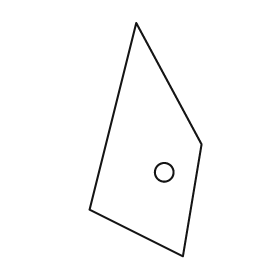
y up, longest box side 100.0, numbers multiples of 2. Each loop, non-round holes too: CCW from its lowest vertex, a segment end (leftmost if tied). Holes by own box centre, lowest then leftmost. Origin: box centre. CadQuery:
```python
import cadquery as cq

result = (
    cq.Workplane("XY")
    .moveTo(16.0, -50.0)
    .lineTo(24.0, -2.0)
    .lineTo(-4.0, 50.0)
    .lineTo(-24.0, -30.0)
    .close()
    .moveTo(8.0, -14.0)
    .circle(4.0)
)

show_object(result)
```